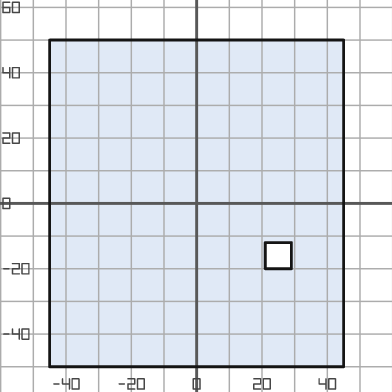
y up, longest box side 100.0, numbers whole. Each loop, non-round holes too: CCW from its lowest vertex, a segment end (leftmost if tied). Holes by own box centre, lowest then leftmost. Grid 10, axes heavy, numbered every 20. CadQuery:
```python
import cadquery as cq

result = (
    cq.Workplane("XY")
    .moveTo(-45.0, -50.0)
    .lineTo(45.0, -50.0)
    .lineTo(45.0, 50.0)
    .lineTo(-45.0, 50.0)
    .close()
    .moveTo(21.0, -20.0)
    .lineTo(29.0, -20.0)
    .lineTo(29.0, -12.0)
    .lineTo(21.0, -12.0)
    .close()
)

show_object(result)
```